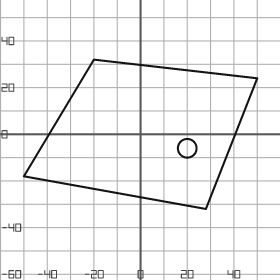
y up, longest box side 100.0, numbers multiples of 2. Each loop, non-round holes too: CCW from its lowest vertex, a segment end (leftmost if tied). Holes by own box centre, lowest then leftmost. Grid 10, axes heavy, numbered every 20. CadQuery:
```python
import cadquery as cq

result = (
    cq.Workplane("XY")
    .moveTo(28.0, -32.0)
    .lineTo(50.0, 24.0)
    .lineTo(-20.0, 32.0)
    .lineTo(-50.0, -18.0)
    .close()
    .moveTo(20.0, -6.0)
    .circle(4.0)
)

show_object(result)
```